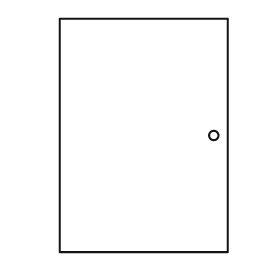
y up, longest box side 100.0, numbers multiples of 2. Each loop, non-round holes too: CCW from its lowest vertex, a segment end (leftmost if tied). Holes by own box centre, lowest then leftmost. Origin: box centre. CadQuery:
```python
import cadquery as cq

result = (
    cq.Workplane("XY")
    .moveTo(-36.0, -50.0)
    .lineTo(36.0, -50.0)
    .lineTo(36.0, 50.0)
    .lineTo(-36.0, 50.0)
    .close()
    .moveTo(30.0, 0.0)
    .circle(2.0)
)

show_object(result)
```